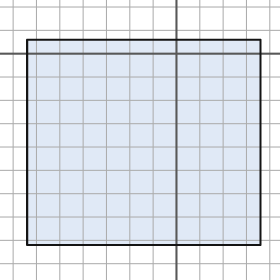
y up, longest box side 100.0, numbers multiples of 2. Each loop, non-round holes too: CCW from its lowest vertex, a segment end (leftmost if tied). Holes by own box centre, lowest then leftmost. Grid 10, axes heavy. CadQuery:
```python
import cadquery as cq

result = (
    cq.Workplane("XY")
    .moveTo(-64.0, -82.0)
    .lineTo(36.0, -82.0)
    .lineTo(36.0, 6.0)
    .lineTo(-64.0, 6.0)
    .close()
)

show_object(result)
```